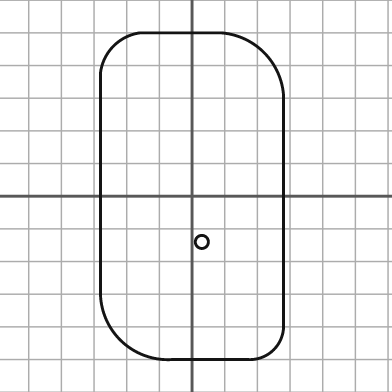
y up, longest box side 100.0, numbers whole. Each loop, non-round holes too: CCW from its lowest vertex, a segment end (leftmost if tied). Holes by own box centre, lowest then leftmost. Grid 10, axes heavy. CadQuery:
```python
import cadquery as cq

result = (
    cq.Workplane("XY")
    .moveTo(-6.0, -50.0)
    .lineTo(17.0, -50.0)
    .threePointArc((25.0, -47.0), (28.0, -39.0))
    .lineTo(28.0, 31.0)
    .threePointArc((22.0, 44.0), (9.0, 50.0))
    .lineTo(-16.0, 50.0)
    .threePointArc((-24.0, 46.0), (-28.0, 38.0))
    .lineTo(-28.0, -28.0)
    .threePointArc((-22.0, -44.0), (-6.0, -50.0))
    .close()
    .moveTo(3.0, -14.0)
    .circle(2.0)
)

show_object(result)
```